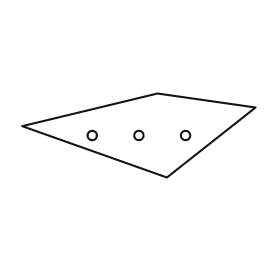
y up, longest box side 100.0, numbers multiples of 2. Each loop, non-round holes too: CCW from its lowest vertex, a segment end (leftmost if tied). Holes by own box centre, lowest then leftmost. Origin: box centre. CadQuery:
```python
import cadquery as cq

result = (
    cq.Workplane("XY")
    .moveTo(12.0, -18.0)
    .lineTo(50.0, 12.0)
    .lineTo(8.0, 18.0)
    .lineTo(-50.0, 4.0)
    .close()
    .moveTo(-20.0, 0.0)
    .circle(2.0)
    .moveTo(0.0, 0.0)
    .circle(2.0)
    .moveTo(20.0, 0.0)
    .circle(2.0)
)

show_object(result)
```